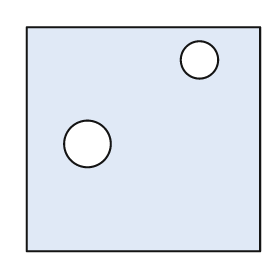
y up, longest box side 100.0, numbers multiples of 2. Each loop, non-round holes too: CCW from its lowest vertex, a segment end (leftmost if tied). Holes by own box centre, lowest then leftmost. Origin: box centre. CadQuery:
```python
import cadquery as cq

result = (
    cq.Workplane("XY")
    .moveTo(-50.0, -48.0)
    .lineTo(50.0, -48.0)
    .lineTo(50.0, 48.0)
    .lineTo(-50.0, 48.0)
    .close()
    .moveTo(-24.0, -2.0)
    .circle(10.0)
    .moveTo(24.0, 34.0)
    .circle(8.0)
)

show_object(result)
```